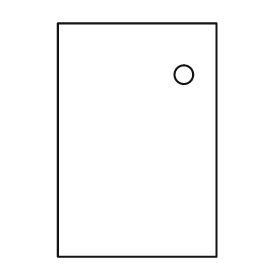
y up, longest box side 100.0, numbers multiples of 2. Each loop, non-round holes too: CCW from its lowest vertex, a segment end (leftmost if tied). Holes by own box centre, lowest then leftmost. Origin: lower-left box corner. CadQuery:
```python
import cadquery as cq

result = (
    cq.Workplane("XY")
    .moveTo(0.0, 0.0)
    .lineTo(68.0, 0.0)
    .lineTo(68.0, 100.0)
    .lineTo(0.0, 100.0)
    .close()
    .moveTo(54.0, 78.0)
    .circle(4.0)
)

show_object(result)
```